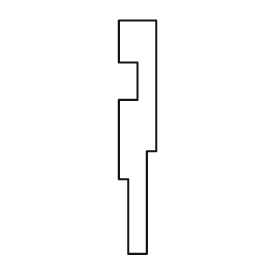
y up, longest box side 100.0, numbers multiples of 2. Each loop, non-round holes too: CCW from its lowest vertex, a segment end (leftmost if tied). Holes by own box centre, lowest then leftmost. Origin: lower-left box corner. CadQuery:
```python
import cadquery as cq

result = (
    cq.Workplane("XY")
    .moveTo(4.0, 0.0)
    .lineTo(12.0, 0.0)
    .lineTo(12.0, 44.0)
    .lineTo(16.0, 44.0)
    .lineTo(16.0, 100.0)
    .lineTo(0.0, 100.0)
    .lineTo(0.0, 82.0)
    .lineTo(8.0, 82.0)
    .lineTo(8.0, 66.0)
    .lineTo(0.0, 66.0)
    .lineTo(0.0, 32.0)
    .lineTo(4.0, 32.0)
    .close()
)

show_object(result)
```